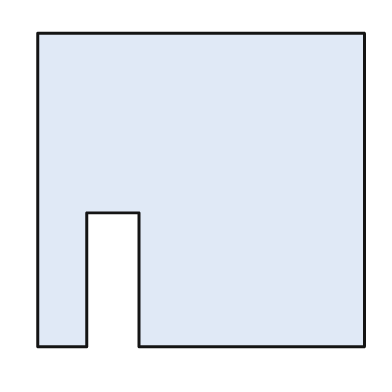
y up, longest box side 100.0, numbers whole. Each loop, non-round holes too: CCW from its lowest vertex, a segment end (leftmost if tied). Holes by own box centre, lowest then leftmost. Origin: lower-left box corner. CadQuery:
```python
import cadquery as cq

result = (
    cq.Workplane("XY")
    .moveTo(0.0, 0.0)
    .lineTo(15.0, 0.0)
    .lineTo(15.0, 41.0)
    .lineTo(31.0, 41.0)
    .lineTo(31.0, 0.0)
    .lineTo(100.0, 0.0)
    .lineTo(100.0, 96.0)
    .lineTo(0.0, 96.0)
    .close()
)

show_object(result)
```